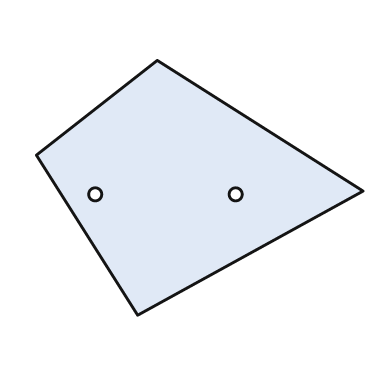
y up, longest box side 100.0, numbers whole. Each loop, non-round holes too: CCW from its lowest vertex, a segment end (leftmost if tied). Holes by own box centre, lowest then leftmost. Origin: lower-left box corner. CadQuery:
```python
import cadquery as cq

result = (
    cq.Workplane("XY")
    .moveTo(31.0, 0.0)
    .lineTo(100.0, 38.0)
    .lineTo(37.0, 78.0)
    .lineTo(0.0, 49.0)
    .close()
    .moveTo(18.0, 37.0)
    .circle(2.0)
    .moveTo(61.0, 37.0)
    .circle(2.0)
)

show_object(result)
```